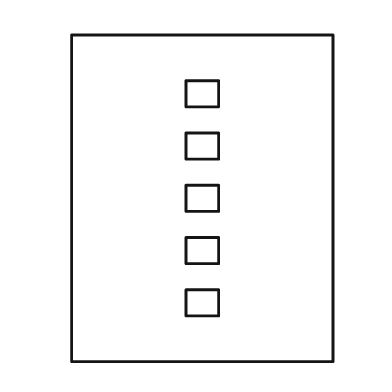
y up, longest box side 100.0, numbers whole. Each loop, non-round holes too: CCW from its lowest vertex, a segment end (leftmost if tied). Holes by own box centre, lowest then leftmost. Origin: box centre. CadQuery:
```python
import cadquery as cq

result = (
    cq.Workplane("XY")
    .moveTo(-40.0, -50.0)
    .lineTo(40.0, -50.0)
    .lineTo(40.0, 50.0)
    .lineTo(-40.0, 50.0)
    .close()
    .moveTo(-5.0, -36.0)
    .lineTo(5.0, -36.0)
    .lineTo(5.0, -28.0)
    .lineTo(-5.0, -28.0)
    .close()
    .moveTo(-5.0, -20.0)
    .lineTo(5.0, -20.0)
    .lineTo(5.0, -12.0)
    .lineTo(-5.0, -12.0)
    .close()
    .moveTo(-5.0, -4.0)
    .lineTo(5.0, -4.0)
    .lineTo(5.0, 4.0)
    .lineTo(-5.0, 4.0)
    .close()
    .moveTo(-5.0, 12.0)
    .lineTo(5.0, 12.0)
    .lineTo(5.0, 20.0)
    .lineTo(-5.0, 20.0)
    .close()
    .moveTo(-5.0, 28.0)
    .lineTo(5.0, 28.0)
    .lineTo(5.0, 36.0)
    .lineTo(-5.0, 36.0)
    .close()
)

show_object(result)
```